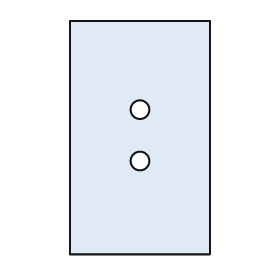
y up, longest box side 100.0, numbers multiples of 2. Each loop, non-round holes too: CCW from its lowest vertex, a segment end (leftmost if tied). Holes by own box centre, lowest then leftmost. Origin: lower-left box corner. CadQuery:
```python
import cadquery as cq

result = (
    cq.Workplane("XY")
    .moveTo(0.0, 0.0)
    .lineTo(60.0, 0.0)
    .lineTo(60.0, 100.0)
    .lineTo(0.0, 100.0)
    .close()
    .moveTo(30.0, 40.0)
    .circle(4.0)
    .moveTo(30.0, 62.0)
    .circle(4.0)
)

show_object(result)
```